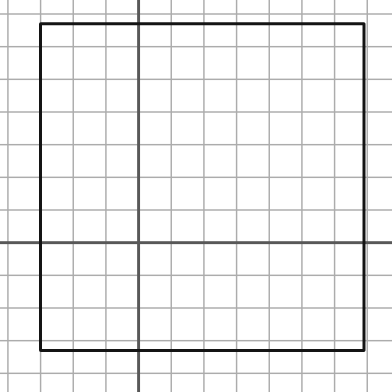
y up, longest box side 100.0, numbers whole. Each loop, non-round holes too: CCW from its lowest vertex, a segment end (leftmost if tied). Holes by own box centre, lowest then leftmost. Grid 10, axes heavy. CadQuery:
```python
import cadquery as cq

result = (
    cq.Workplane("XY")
    .moveTo(-30.0, -33.0)
    .lineTo(69.0, -33.0)
    .lineTo(69.0, 67.0)
    .lineTo(-30.0, 67.0)
    .close()
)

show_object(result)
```